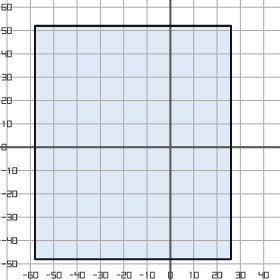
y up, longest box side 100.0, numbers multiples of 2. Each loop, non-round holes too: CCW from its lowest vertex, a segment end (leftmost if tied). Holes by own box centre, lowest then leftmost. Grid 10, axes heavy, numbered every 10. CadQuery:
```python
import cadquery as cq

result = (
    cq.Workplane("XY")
    .moveTo(-58.0, -48.0)
    .lineTo(26.0, -48.0)
    .lineTo(26.0, 52.0)
    .lineTo(-58.0, 52.0)
    .close()
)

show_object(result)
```